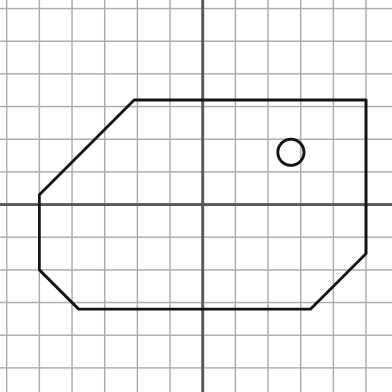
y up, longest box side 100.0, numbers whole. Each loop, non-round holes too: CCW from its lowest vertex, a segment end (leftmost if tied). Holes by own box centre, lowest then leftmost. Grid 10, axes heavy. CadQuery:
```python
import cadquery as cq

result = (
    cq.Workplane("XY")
    .moveTo(-38.0, -32.0)
    .lineTo(33.0, -32.0)
    .lineTo(50.0, -15.0)
    .lineTo(50.0, 32.0)
    .lineTo(-21.0, 32.0)
    .lineTo(-50.0, 3.0)
    .lineTo(-50.0, -20.0)
    .close()
    .moveTo(27.0, 16.0)
    .circle(4.0)
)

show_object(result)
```